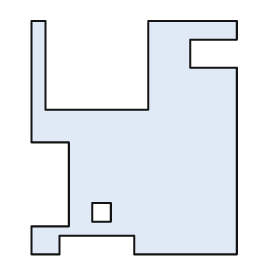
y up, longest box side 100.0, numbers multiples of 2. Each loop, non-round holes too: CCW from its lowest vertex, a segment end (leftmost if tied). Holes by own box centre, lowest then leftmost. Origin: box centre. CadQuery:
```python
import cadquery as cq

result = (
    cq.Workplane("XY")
    .moveTo(-44.0, -50.0)
    .lineTo(-32.0, -50.0)
    .lineTo(-32.0, -42.0)
    .lineTo(0.0, -42.0)
    .lineTo(0.0, -50.0)
    .lineTo(44.0, -50.0)
    .lineTo(44.0, 30.0)
    .lineTo(24.0, 30.0)
    .lineTo(24.0, 42.0)
    .lineTo(44.0, 42.0)
    .lineTo(44.0, 50.0)
    .lineTo(6.0, 50.0)
    .lineTo(6.0, 12.0)
    .lineTo(-38.0, 12.0)
    .lineTo(-38.0, 50.0)
    .lineTo(-44.0, 50.0)
    .lineTo(-44.0, -2.0)
    .lineTo(-28.0, -2.0)
    .lineTo(-28.0, -38.0)
    .lineTo(-44.0, -38.0)
    .close()
    .moveTo(-18.0, -36.0)
    .lineTo(-10.0, -36.0)
    .lineTo(-10.0, -28.0)
    .lineTo(-18.0, -28.0)
    .close()
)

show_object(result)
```